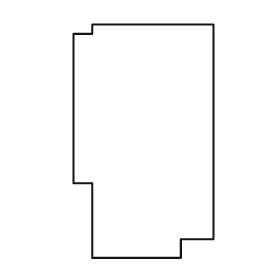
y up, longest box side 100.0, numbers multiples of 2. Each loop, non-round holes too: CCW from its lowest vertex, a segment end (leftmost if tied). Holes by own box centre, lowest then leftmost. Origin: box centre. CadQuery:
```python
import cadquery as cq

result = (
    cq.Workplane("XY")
    .moveTo(-22.0, -50.0)
    .lineTo(16.0, -50.0)
    .lineTo(16.0, -42.0)
    .lineTo(30.0, -42.0)
    .lineTo(30.0, 50.0)
    .lineTo(-22.0, 50.0)
    .lineTo(-22.0, 46.0)
    .lineTo(-30.0, 46.0)
    .lineTo(-30.0, -18.0)
    .lineTo(-22.0, -18.0)
    .close()
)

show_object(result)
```